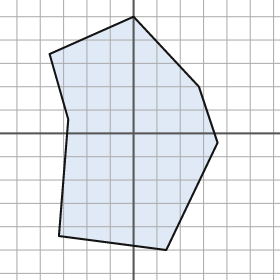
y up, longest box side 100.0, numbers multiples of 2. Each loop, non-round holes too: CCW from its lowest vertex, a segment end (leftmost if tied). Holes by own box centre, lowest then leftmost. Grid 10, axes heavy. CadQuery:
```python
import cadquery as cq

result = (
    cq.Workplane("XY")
    .moveTo(14.0, -50.0)
    .lineTo(36.0, -4.0)
    .lineTo(28.0, 20.0)
    .lineTo(0.0, 50.0)
    .lineTo(-36.0, 34.0)
    .lineTo(-28.0, 6.0)
    .lineTo(-32.0, -44.0)
    .close()
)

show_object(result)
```